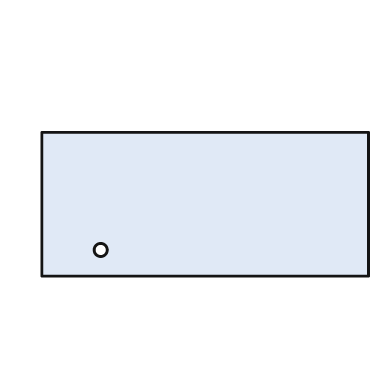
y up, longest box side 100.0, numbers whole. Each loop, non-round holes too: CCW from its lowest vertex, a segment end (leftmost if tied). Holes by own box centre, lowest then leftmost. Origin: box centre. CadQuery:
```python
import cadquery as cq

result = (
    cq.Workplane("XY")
    .moveTo(-50.0, -22.0)
    .lineTo(50.0, -22.0)
    .lineTo(50.0, 22.0)
    .lineTo(-50.0, 22.0)
    .close()
    .moveTo(-32.0, -14.0)
    .circle(2.0)
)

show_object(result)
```